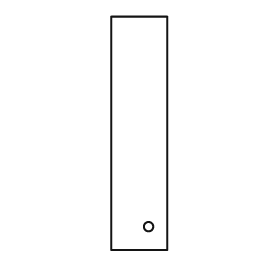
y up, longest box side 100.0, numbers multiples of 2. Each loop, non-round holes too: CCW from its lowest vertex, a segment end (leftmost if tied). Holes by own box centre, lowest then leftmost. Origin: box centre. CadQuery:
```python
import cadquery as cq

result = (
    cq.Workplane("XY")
    .moveTo(-12.0, -50.0)
    .lineTo(12.0, -50.0)
    .lineTo(12.0, 50.0)
    .lineTo(-12.0, 50.0)
    .close()
    .moveTo(4.0, -40.0)
    .circle(2.0)
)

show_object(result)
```